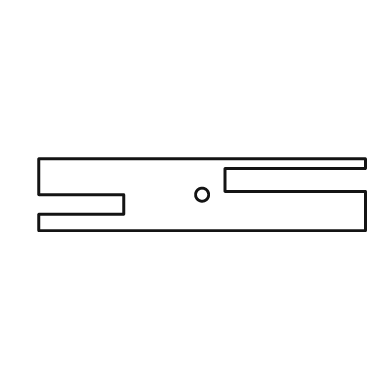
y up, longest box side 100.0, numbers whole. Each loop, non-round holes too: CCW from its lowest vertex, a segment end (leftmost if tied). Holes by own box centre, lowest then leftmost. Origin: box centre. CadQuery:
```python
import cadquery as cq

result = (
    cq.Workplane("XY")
    .moveTo(-50.0, -11.0)
    .lineTo(50.0, -11.0)
    .lineTo(50.0, 1.0)
    .lineTo(7.0, 1.0)
    .lineTo(7.0, 8.0)
    .lineTo(50.0, 8.0)
    .lineTo(50.0, 11.0)
    .lineTo(-50.0, 11.0)
    .lineTo(-50.0, 0.0)
    .lineTo(-24.0, 0.0)
    .lineTo(-24.0, -6.0)
    .lineTo(-50.0, -6.0)
    .close()
    .moveTo(0.0, 0.0)
    .circle(2.0)
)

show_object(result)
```